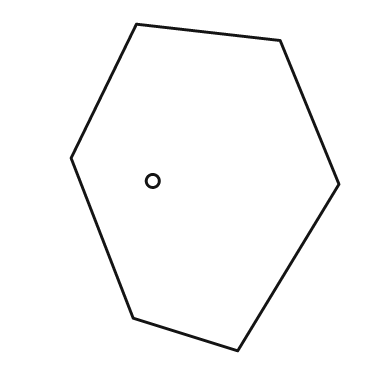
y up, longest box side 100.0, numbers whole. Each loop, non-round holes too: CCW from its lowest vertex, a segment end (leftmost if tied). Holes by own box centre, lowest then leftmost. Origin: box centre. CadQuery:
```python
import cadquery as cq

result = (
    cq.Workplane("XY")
    .moveTo(10.0, -50.0)
    .lineTo(41.0, 1.0)
    .lineTo(23.0, 45.0)
    .lineTo(-21.0, 50.0)
    .lineTo(-41.0, 9.0)
    .lineTo(-22.0, -40.0)
    .close()
    .moveTo(-16.0, 2.0)
    .circle(2.0)
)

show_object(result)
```